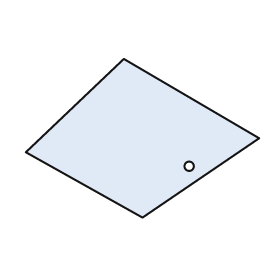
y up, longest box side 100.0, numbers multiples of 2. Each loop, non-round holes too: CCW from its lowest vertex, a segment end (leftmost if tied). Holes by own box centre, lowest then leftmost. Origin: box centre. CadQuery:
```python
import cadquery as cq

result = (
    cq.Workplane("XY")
    .moveTo(0.0, -34.0)
    .lineTo(50.0, 0.0)
    .lineTo(-8.0, 34.0)
    .lineTo(-50.0, -6.0)
    .close()
    .moveTo(20.0, -12.0)
    .circle(2.0)
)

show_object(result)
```